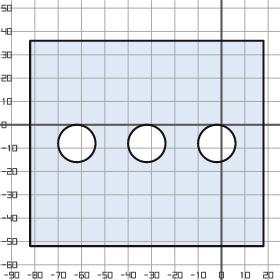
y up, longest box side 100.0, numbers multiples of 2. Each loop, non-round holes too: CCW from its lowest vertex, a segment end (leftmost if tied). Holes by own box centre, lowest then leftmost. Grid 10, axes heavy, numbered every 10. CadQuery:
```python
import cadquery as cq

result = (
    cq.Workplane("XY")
    .moveTo(-82.0, -52.0)
    .lineTo(18.0, -52.0)
    .lineTo(18.0, 36.0)
    .lineTo(-82.0, 36.0)
    .close()
    .moveTo(-62.0, -8.0)
    .circle(8.0)
    .moveTo(-32.0, -8.0)
    .circle(8.0)
    .moveTo(-2.0, -8.0)
    .circle(8.0)
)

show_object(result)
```